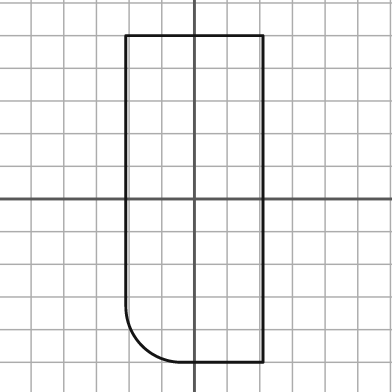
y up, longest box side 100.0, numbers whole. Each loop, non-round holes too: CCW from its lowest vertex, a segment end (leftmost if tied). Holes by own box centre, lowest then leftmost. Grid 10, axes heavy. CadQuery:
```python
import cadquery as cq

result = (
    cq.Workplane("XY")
    .moveTo(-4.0, -50.0)
    .lineTo(21.0, -50.0)
    .lineTo(21.0, 50.0)
    .lineTo(-21.0, 50.0)
    .lineTo(-21.0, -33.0)
    .threePointArc((-16.0, -45.0), (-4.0, -50.0))
    .close()
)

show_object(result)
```